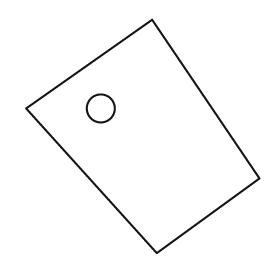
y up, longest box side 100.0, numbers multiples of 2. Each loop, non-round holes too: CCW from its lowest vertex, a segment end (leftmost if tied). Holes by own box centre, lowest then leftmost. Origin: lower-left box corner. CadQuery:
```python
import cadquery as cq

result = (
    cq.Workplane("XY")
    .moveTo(56.0, 0.0)
    .lineTo(100.0, 32.0)
    .lineTo(54.0, 100.0)
    .lineTo(0.0, 62.0)
    .close()
    .moveTo(32.0, 62.0)
    .circle(6.0)
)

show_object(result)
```